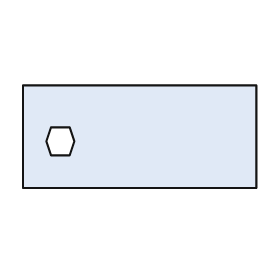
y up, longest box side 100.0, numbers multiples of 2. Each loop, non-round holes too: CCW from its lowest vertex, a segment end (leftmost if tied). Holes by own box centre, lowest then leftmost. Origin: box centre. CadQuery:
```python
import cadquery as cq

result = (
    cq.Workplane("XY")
    .moveTo(-50.0, -22.0)
    .lineTo(50.0, -22.0)
    .lineTo(50.0, 22.0)
    .lineTo(-50.0, 22.0)
    .close()
    .moveTo(-38.0, -8.0)
    .lineTo(-30.0, -8.0)
    .lineTo(-28.0, -2.0)
    .lineTo(-30.0, 4.0)
    .lineTo(-38.0, 4.0)
    .lineTo(-40.0, -2.0)
    .close()
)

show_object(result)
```